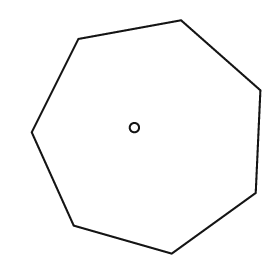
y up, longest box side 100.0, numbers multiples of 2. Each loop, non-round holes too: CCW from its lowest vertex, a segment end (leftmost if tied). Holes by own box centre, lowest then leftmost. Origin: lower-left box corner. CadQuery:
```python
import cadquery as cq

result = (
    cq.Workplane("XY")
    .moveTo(60.0, 0.0)
    .lineTo(96.0, 26.0)
    .lineTo(98.0, 70.0)
    .lineTo(64.0, 100.0)
    .lineTo(20.0, 92.0)
    .lineTo(0.0, 52.0)
    .lineTo(18.0, 12.0)
    .close()
    .moveTo(44.0, 54.0)
    .circle(2.0)
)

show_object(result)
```